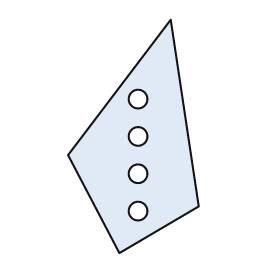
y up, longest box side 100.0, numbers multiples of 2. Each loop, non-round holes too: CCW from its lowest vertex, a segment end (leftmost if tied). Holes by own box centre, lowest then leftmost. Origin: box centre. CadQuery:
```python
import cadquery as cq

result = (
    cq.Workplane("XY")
    .moveTo(-6.0, -50.0)
    .lineTo(28.0, -30.0)
    .lineTo(16.0, 50.0)
    .lineTo(-28.0, -8.0)
    .close()
    .moveTo(2.0, -32.0)
    .circle(4.0)
    .moveTo(2.0, -16.0)
    .circle(4.0)
    .moveTo(2.0, 0.0)
    .circle(4.0)
    .moveTo(2.0, 16.0)
    .circle(4.0)
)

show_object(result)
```